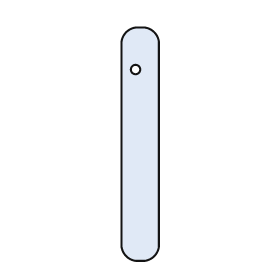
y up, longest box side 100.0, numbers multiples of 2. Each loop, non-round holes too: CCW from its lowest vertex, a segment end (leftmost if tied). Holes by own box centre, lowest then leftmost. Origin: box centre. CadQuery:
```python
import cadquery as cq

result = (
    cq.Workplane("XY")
    .moveTo(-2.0, -50.0)
    .lineTo(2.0, -50.0)
    .threePointArc((6.0, -48.0), (8.0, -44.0))
    .lineTo(8.0, 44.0)
    .threePointArc((6.0, 48.0), (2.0, 50.0))
    .lineTo(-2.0, 50.0)
    .threePointArc((-6.0, 48.0), (-8.0, 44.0))
    .lineTo(-8.0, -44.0)
    .threePointArc((-6.0, -48.0), (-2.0, -50.0))
    .close()
    .moveTo(-2.0, 32.0)
    .circle(2.0)
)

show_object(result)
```